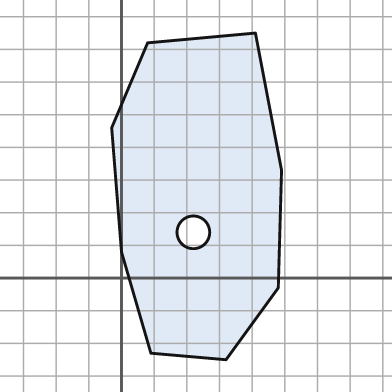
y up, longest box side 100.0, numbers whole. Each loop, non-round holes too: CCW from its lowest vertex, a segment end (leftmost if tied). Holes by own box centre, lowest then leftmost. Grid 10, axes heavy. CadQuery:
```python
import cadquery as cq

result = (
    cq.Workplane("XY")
    .moveTo(32.0, -25.0)
    .lineTo(48.0, -3.0)
    .lineTo(49.0, 33.0)
    .lineTo(41.0, 75.0)
    .lineTo(8.0, 72.0)
    .lineTo(-3.0, 46.0)
    .lineTo(0.0, 8.0)
    .lineTo(9.0, -23.0)
    .close()
    .moveTo(22.0, 14.0)
    .circle(5.0)
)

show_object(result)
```